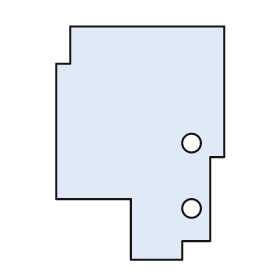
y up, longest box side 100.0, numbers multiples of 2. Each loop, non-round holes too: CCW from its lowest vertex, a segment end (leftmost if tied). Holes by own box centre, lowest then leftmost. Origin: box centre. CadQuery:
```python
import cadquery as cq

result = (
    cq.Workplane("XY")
    .moveTo(-4.0, -50.0)
    .lineTo(18.0, -50.0)
    .lineTo(18.0, -42.0)
    .lineTo(30.0, -42.0)
    .lineTo(30.0, -6.0)
    .lineTo(36.0, -6.0)
    .lineTo(36.0, 50.0)
    .lineTo(-30.0, 50.0)
    .lineTo(-30.0, 34.0)
    .lineTo(-36.0, 34.0)
    .lineTo(-36.0, -24.0)
    .lineTo(-4.0, -24.0)
    .close()
    .moveTo(22.0, -28.0)
    .circle(4.0)
    .moveTo(22.0, 0.0)
    .circle(4.0)
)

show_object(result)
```